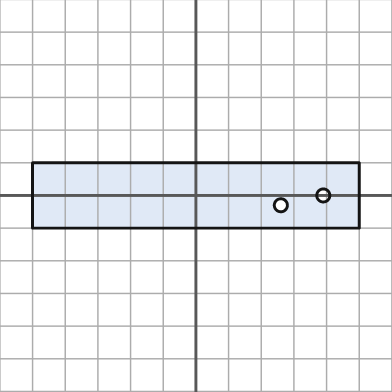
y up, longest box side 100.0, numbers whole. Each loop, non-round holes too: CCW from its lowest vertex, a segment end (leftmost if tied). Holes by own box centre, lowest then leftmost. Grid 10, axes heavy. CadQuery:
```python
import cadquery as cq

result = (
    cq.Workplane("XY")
    .moveTo(-50.0, -10.0)
    .lineTo(50.0, -10.0)
    .lineTo(50.0, 10.0)
    .lineTo(-50.0, 10.0)
    .close()
    .moveTo(26.0, -3.0)
    .circle(2.0)
    .moveTo(39.0, 0.0)
    .circle(2.0)
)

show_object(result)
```